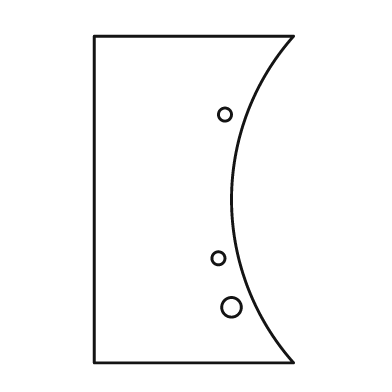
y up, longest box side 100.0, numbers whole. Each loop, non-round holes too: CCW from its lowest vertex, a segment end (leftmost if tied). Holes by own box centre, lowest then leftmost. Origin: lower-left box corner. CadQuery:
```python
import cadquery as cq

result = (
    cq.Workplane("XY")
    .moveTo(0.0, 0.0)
    .lineTo(61.0, 0.0)
    .threePointArc((42.0, 50.0), (61.0, 100.0))
    .lineTo(0.0, 100.0)
    .close()
    .moveTo(42.0, 17.0)
    .circle(3.0)
    .moveTo(38.0, 32.0)
    .circle(2.0)
    .moveTo(40.0, 76.0)
    .circle(2.0)
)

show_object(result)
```